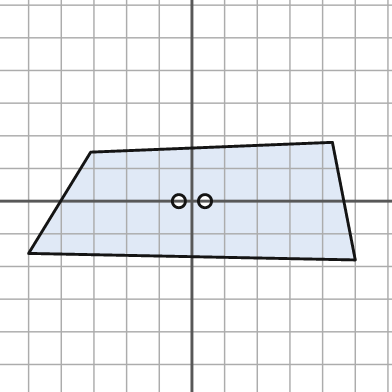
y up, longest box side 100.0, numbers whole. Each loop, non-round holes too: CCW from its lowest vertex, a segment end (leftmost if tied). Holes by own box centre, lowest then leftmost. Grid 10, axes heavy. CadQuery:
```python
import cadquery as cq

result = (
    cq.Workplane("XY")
    .moveTo(50.0, -18.0)
    .lineTo(43.0, 18.0)
    .lineTo(-31.0, 15.0)
    .lineTo(-50.0, -16.0)
    .close()
    .moveTo(-4.0, 0.0)
    .circle(2.0)
    .moveTo(4.0, 0.0)
    .circle(2.0)
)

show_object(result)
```